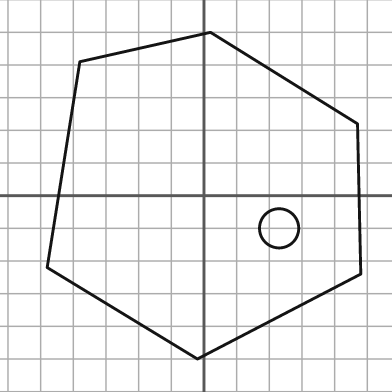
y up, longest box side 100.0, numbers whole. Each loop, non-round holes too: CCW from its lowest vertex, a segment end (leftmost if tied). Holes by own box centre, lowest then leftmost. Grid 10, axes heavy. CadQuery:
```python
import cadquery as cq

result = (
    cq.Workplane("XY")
    .moveTo(-2.0, -50.0)
    .lineTo(48.0, -24.0)
    .lineTo(47.0, 22.0)
    .lineTo(2.0, 50.0)
    .lineTo(-38.0, 41.0)
    .lineTo(-48.0, -22.0)
    .close()
    .moveTo(23.0, -10.0)
    .circle(6.0)
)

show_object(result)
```